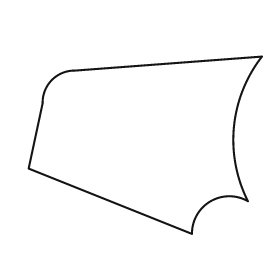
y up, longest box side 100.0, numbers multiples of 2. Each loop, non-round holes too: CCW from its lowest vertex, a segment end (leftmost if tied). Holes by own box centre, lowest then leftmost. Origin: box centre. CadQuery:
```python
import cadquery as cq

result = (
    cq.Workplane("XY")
    .moveTo(20.0, -38.0)
    .threePointArc((28.0, -24.0), (44.0, -24.0))
    .threePointArc((38.0, 8.0), (50.0, 38.0))
    .lineTo(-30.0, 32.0)
    .threePointArc((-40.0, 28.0), (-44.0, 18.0))
    .lineTo(-50.0, -10.0)
    .close()
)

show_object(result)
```